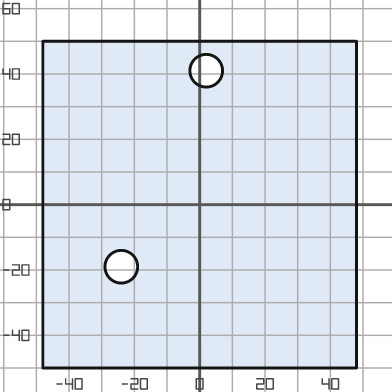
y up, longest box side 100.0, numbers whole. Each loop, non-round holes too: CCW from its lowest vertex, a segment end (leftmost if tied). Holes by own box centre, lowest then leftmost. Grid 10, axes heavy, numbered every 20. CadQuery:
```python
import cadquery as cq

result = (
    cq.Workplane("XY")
    .moveTo(-48.0, -50.0)
    .lineTo(48.0, -50.0)
    .lineTo(48.0, 50.0)
    .lineTo(-48.0, 50.0)
    .close()
    .moveTo(-24.0, -19.0)
    .circle(5.0)
    .moveTo(2.0, 41.0)
    .circle(5.0)
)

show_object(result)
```